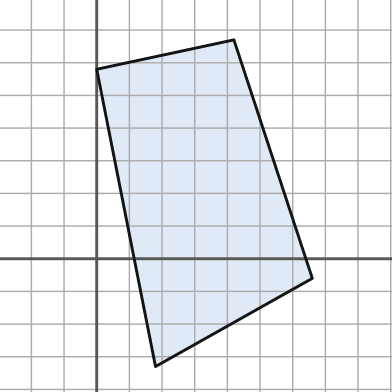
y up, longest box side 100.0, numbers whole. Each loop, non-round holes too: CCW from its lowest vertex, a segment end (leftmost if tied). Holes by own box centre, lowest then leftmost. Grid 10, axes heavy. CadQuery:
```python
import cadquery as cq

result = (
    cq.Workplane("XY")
    .moveTo(18.0, -33.0)
    .lineTo(66.0, -6.0)
    .lineTo(42.0, 67.0)
    .lineTo(0.0, 58.0)
    .close()
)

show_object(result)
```